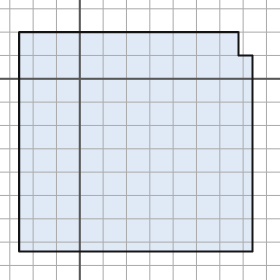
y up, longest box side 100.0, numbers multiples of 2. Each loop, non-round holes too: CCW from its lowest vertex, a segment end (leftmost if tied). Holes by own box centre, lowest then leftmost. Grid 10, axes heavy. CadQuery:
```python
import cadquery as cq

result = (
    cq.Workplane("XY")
    .moveTo(-26.0, -74.0)
    .lineTo(74.0, -74.0)
    .lineTo(74.0, 10.0)
    .lineTo(68.0, 10.0)
    .lineTo(68.0, 20.0)
    .lineTo(-26.0, 20.0)
    .close()
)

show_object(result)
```